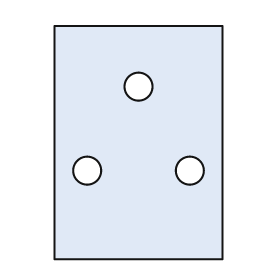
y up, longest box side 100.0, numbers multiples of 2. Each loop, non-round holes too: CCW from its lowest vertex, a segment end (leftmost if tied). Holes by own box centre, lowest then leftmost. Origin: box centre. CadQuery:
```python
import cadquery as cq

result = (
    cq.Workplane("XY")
    .moveTo(-36.0, -50.0)
    .lineTo(36.0, -50.0)
    .lineTo(36.0, 50.0)
    .lineTo(-36.0, 50.0)
    .close()
    .moveTo(-22.0, -12.0)
    .circle(6.0)
    .moveTo(22.0, -12.0)
    .circle(6.0)
    .moveTo(0.0, 24.0)
    .circle(6.0)
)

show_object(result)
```